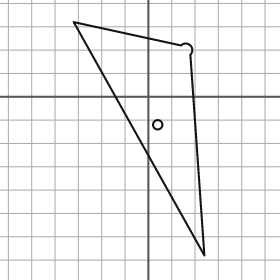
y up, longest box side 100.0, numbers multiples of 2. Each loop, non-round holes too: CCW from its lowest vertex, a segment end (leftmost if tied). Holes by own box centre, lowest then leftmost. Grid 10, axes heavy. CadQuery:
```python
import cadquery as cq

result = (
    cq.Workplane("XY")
    .moveTo(24.0, -68.0)
    .lineTo(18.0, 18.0)
    .threePointArc((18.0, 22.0), (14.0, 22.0))
    .lineTo(-32.0, 32.0)
    .close()
    .moveTo(4.0, -12.0)
    .circle(2.0)
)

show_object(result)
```